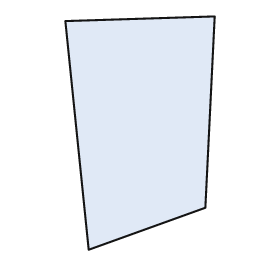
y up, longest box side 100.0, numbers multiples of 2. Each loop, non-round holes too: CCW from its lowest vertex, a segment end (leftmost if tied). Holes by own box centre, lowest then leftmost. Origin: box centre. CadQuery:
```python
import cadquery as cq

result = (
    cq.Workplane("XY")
    .moveTo(-22.0, -50.0)
    .lineTo(28.0, -32.0)
    .lineTo(32.0, 50.0)
    .lineTo(-32.0, 48.0)
    .close()
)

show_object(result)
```